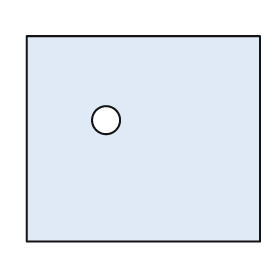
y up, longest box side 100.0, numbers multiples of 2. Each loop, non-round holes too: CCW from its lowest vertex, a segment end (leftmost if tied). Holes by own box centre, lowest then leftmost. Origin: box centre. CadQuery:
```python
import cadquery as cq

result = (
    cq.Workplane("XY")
    .moveTo(-50.0, -44.0)
    .lineTo(50.0, -44.0)
    .lineTo(50.0, 44.0)
    .lineTo(-50.0, 44.0)
    .close()
    .moveTo(-16.0, 8.0)
    .circle(6.0)
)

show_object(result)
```